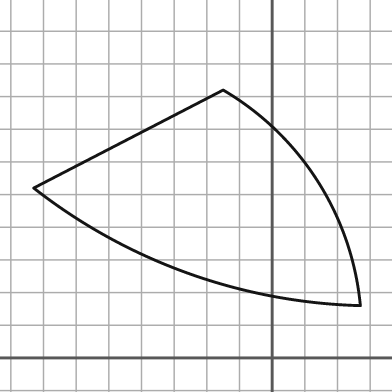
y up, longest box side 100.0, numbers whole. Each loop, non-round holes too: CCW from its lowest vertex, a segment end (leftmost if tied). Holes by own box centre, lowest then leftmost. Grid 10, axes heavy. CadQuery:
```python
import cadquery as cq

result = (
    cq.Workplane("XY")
    .moveTo(27.0, 16.0)
    .threePointArc((14.0, 54.0), (-15.0, 82.0))
    .lineTo(-73.0, 52.0)
    .threePointArc((-26.0, 26.0), (27.0, 16.0))
    .close()
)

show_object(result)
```